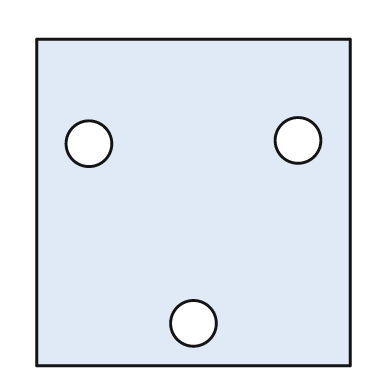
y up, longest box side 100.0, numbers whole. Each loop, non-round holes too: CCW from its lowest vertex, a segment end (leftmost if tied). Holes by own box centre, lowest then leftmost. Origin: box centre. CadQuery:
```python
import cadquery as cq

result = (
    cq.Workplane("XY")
    .moveTo(-48.0, -50.0)
    .lineTo(48.0, -50.0)
    .lineTo(48.0, 50.0)
    .lineTo(-48.0, 50.0)
    .close()
    .moveTo(0.0, -37.0)
    .circle(7.0)
    .moveTo(-32.0, 18.0)
    .circle(7.0)
    .moveTo(32.0, 19.0)
    .circle(7.0)
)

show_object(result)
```